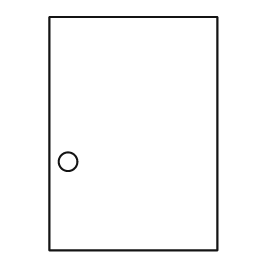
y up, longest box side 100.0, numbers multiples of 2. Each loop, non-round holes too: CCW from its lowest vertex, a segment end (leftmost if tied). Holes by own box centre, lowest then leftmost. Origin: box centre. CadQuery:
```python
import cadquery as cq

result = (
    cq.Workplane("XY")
    .moveTo(-36.0, -50.0)
    .lineTo(36.0, -50.0)
    .lineTo(36.0, 50.0)
    .lineTo(-36.0, 50.0)
    .close()
    .moveTo(-28.0, -12.0)
    .circle(4.0)
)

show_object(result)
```